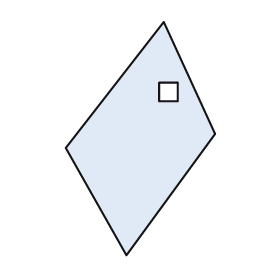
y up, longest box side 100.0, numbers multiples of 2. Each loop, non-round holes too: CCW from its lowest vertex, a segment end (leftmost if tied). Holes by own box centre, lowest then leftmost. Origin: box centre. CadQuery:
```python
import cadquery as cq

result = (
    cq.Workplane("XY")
    .moveTo(-6.0, -50.0)
    .lineTo(32.0, 2.0)
    .lineTo(10.0, 50.0)
    .lineTo(-32.0, -4.0)
    .close()
    .moveTo(8.0, 16.0)
    .lineTo(16.0, 16.0)
    .lineTo(16.0, 24.0)
    .lineTo(8.0, 24.0)
    .close()
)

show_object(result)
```